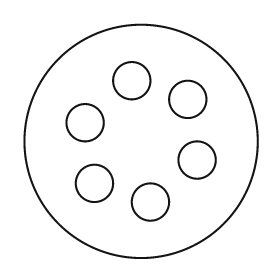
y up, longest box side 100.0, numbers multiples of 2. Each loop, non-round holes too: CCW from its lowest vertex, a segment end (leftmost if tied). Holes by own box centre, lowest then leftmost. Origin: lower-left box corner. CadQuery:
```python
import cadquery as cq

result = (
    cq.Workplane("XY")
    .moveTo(50.0, 50.0)
    .circle(50.0)
    .moveTo(54.0, 24.0)
    .circle(8.0)
    .moveTo(30.0, 32.0)
    .circle(8.0)
    .moveTo(74.0, 42.0)
    .circle(8.0)
    .moveTo(26.0, 58.0)
    .circle(8.0)
    .moveTo(70.0, 68.0)
    .circle(8.0)
    .moveTo(46.0, 76.0)
    .circle(8.0)
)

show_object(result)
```